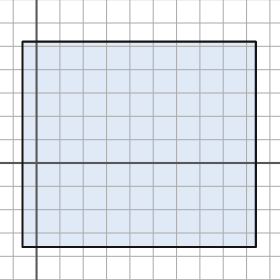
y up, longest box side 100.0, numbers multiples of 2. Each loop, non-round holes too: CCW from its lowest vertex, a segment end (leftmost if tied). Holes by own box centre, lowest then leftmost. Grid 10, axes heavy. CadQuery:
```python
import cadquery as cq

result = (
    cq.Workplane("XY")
    .moveTo(-6.0, -36.0)
    .lineTo(94.0, -36.0)
    .lineTo(94.0, 52.0)
    .lineTo(-6.0, 52.0)
    .close()
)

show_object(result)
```